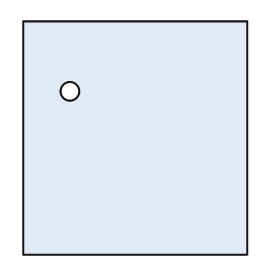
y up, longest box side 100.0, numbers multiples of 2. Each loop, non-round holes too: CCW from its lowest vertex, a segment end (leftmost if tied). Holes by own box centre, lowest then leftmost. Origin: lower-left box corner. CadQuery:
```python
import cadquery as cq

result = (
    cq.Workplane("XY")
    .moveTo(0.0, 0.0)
    .lineTo(96.0, 0.0)
    .lineTo(96.0, 100.0)
    .lineTo(0.0, 100.0)
    .close()
    .moveTo(20.0, 70.0)
    .circle(4.0)
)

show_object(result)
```